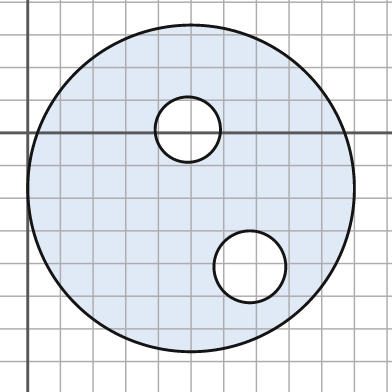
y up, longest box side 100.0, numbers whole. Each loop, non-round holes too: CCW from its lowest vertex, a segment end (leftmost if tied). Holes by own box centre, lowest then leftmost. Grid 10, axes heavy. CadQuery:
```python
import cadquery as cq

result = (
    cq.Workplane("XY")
    .moveTo(50.0, -17.0)
    .circle(50.0)
    .moveTo(68.0, -41.0)
    .circle(11.0)
    .moveTo(49.0, 1.0)
    .circle(10.0)
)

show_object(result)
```